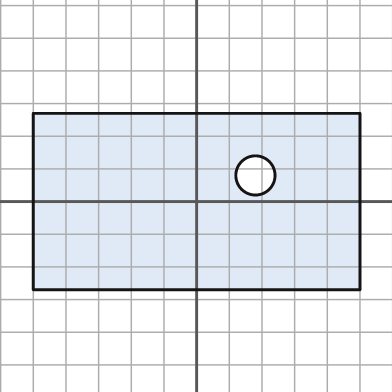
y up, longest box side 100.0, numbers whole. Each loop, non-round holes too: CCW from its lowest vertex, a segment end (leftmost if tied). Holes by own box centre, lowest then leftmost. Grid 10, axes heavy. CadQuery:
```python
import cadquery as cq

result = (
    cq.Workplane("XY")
    .moveTo(-50.0, -27.0)
    .lineTo(50.0, -27.0)
    .lineTo(50.0, 27.0)
    .lineTo(-50.0, 27.0)
    .close()
    .moveTo(18.0, 8.0)
    .circle(6.0)
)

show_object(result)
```